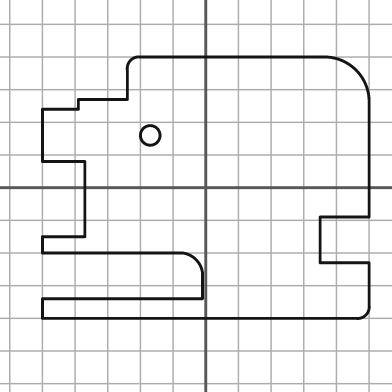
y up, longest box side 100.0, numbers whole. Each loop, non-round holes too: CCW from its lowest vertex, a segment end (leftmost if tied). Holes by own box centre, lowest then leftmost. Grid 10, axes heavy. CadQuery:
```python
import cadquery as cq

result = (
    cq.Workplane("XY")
    .moveTo(-50.0, -40.0)
    .lineTo(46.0, -40.0)
    .threePointArc((49.0, -39.0), (50.0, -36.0))
    .lineTo(50.0, -23.0)
    .lineTo(35.0, -23.0)
    .lineTo(35.0, -9.0)
    .lineTo(50.0, -9.0)
    .lineTo(50.0, 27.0)
    .threePointArc((46.0, 36.0), (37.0, 40.0))
    .lineTo(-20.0, 40.0)
    .threePointArc((-23.0, 39.0), (-24.0, 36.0))
    .lineTo(-24.0, 27.0)
    .lineTo(-39.0, 27.0)
    .lineTo(-39.0, 24.0)
    .lineTo(-50.0, 24.0)
    .lineTo(-50.0, 8.0)
    .lineTo(-37.0, 8.0)
    .lineTo(-37.0, -15.0)
    .lineTo(-50.0, -15.0)
    .lineTo(-50.0, -20.0)
    .lineTo(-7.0, -20.0)
    .threePointArc((-3.0, -22.0), (-1.0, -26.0))
    .lineTo(-1.0, -34.0)
    .lineTo(-50.0, -34.0)
    .close()
    .moveTo(-17.0, 16.0)
    .circle(3.0)
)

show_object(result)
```